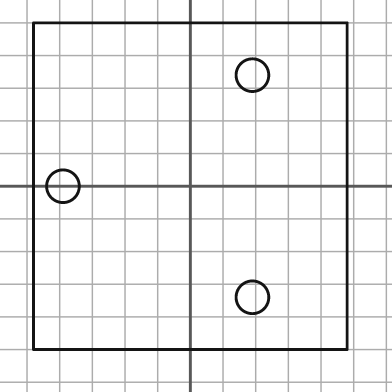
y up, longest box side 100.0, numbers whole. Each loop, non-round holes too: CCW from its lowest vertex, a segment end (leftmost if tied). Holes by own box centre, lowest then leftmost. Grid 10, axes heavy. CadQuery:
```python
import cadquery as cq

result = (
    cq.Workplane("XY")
    .moveTo(-48.0, -50.0)
    .lineTo(48.0, -50.0)
    .lineTo(48.0, 50.0)
    .lineTo(-48.0, 50.0)
    .close()
    .moveTo(19.0, -34.0)
    .circle(5.0)
    .moveTo(-39.0, 0.0)
    .circle(5.0)
    .moveTo(19.0, 34.0)
    .circle(5.0)
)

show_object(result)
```